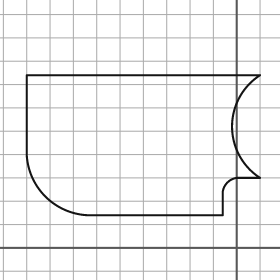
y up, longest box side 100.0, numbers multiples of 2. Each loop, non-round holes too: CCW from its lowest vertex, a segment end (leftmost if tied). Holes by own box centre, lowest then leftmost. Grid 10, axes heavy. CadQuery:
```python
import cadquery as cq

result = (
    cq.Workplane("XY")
    .moveTo(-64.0, 14.0)
    .lineTo(-6.0, 14.0)
    .lineTo(-6.0, 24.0)
    .threePointArc((-4.0, 28.0), (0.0, 30.0))
    .lineTo(10.0, 30.0)
    .threePointArc((-2.0, 52.0), (10.0, 74.0))
    .lineTo(-90.0, 74.0)
    .lineTo(-90.0, 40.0)
    .threePointArc((-82.0, 22.0), (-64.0, 14.0))
    .close()
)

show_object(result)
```